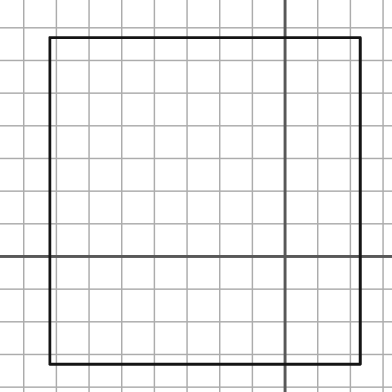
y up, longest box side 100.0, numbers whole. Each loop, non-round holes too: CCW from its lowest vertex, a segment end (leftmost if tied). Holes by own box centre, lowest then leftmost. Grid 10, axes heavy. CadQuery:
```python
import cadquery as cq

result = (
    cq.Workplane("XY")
    .moveTo(-72.0, -33.0)
    .lineTo(23.0, -33.0)
    .lineTo(23.0, 67.0)
    .lineTo(-72.0, 67.0)
    .close()
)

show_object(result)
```